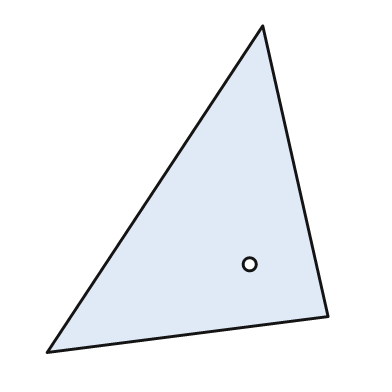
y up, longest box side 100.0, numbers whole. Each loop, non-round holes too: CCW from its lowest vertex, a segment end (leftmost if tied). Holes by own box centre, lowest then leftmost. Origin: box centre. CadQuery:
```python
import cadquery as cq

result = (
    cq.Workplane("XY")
    .moveTo(-43.0, -50.0)
    .lineTo(43.0, -39.0)
    .lineTo(23.0, 50.0)
    .close()
    .moveTo(19.0, -23.0)
    .circle(2.0)
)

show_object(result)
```